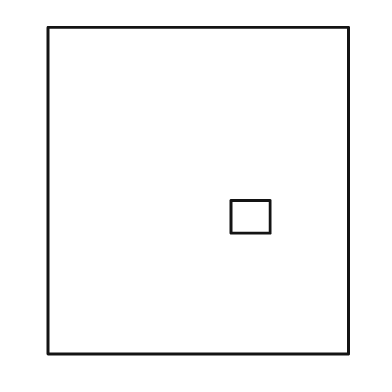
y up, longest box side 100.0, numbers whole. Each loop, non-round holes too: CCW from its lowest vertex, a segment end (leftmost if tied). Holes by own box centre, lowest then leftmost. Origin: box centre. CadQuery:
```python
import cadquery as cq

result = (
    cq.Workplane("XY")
    .moveTo(-46.0, -50.0)
    .lineTo(46.0, -50.0)
    .lineTo(46.0, 50.0)
    .lineTo(-46.0, 50.0)
    .close()
    .moveTo(10.0, -13.0)
    .lineTo(22.0, -13.0)
    .lineTo(22.0, -3.0)
    .lineTo(10.0, -3.0)
    .close()
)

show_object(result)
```